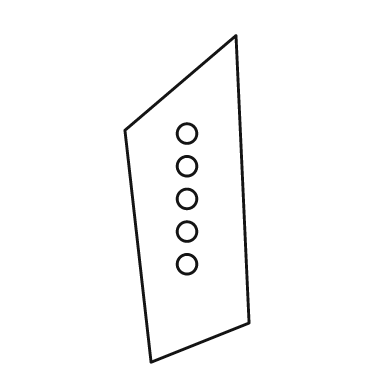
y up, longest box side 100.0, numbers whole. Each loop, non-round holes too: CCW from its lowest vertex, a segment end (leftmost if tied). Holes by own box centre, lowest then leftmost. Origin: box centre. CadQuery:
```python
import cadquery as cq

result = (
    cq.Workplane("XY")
    .moveTo(-11.0, -50.0)
    .lineTo(19.0, -38.0)
    .lineTo(15.0, 50.0)
    .lineTo(-19.0, 21.0)
    .close()
    .moveTo(0.0, -20.0)
    .circle(3.0)
    .moveTo(0.0, -10.0)
    .circle(3.0)
    .moveTo(0.0, 0.0)
    .circle(3.0)
    .moveTo(0.0, 10.0)
    .circle(3.0)
    .moveTo(0.0, 20.0)
    .circle(3.0)
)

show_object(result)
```